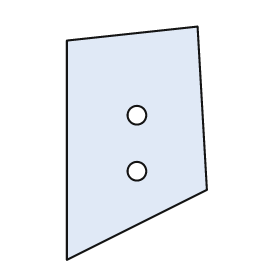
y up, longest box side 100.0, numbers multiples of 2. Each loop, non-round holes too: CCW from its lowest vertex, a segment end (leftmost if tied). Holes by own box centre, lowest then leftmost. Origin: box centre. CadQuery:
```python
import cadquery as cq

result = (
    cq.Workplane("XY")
    .moveTo(-30.0, -50.0)
    .lineTo(30.0, -20.0)
    .lineTo(26.0, 50.0)
    .lineTo(-30.0, 44.0)
    .close()
    .moveTo(0.0, -12.0)
    .circle(4.0)
    .moveTo(0.0, 12.0)
    .circle(4.0)
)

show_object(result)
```